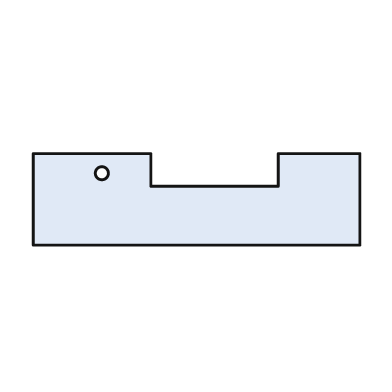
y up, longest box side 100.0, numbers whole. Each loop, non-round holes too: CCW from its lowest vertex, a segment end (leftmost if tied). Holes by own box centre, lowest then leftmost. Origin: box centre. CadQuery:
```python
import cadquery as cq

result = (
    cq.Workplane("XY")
    .moveTo(-50.0, -14.0)
    .lineTo(50.0, -14.0)
    .lineTo(50.0, 14.0)
    .lineTo(25.0, 14.0)
    .lineTo(25.0, 4.0)
    .lineTo(-14.0, 4.0)
    .lineTo(-14.0, 14.0)
    .lineTo(-50.0, 14.0)
    .close()
    .moveTo(-29.0, 8.0)
    .circle(2.0)
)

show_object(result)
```